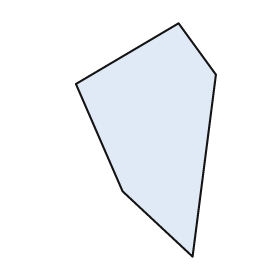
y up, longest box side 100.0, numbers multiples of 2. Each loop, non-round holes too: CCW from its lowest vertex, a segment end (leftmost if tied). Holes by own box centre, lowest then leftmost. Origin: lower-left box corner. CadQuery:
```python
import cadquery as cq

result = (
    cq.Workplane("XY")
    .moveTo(50.0, 0.0)
    .lineTo(60.0, 78.0)
    .lineTo(44.0, 100.0)
    .lineTo(0.0, 74.0)
    .lineTo(20.0, 28.0)
    .close()
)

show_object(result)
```